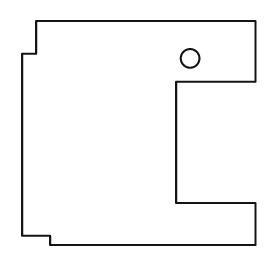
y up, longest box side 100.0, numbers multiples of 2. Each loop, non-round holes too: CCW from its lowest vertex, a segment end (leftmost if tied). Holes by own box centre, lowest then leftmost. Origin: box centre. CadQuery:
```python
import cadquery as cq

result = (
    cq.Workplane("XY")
    .moveTo(-38.0, -48.0)
    .lineTo(50.0, -48.0)
    .lineTo(50.0, -30.0)
    .lineTo(16.0, -30.0)
    .lineTo(16.0, 22.0)
    .lineTo(50.0, 22.0)
    .lineTo(50.0, 48.0)
    .lineTo(-44.0, 48.0)
    .lineTo(-44.0, 34.0)
    .lineTo(-50.0, 34.0)
    .lineTo(-50.0, -44.0)
    .lineTo(-38.0, -44.0)
    .close()
    .moveTo(22.0, 32.0)
    .circle(4.0)
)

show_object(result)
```